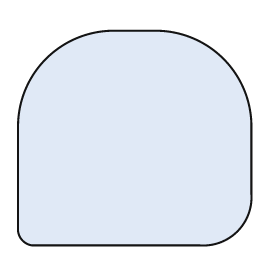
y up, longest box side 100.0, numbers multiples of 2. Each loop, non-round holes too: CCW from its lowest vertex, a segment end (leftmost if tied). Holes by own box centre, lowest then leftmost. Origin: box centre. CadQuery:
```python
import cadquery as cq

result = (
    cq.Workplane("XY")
    .moveTo(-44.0, -46.0)
    .lineTo(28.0, -46.0)
    .threePointArc((44.0, -40.0), (50.0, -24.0))
    .lineTo(50.0, 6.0)
    .threePointArc((38.0, 34.0), (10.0, 46.0))
    .lineTo(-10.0, 46.0)
    .threePointArc((-38.0, 34.0), (-50.0, 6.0))
    .lineTo(-50.0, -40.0)
    .threePointArc((-48.0, -44.0), (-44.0, -46.0))
    .close()
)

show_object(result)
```